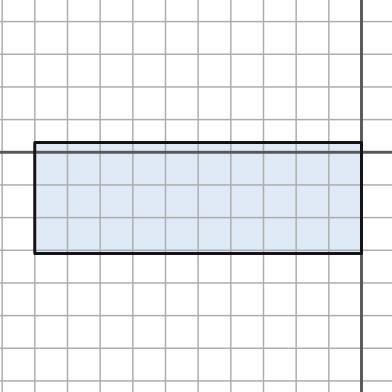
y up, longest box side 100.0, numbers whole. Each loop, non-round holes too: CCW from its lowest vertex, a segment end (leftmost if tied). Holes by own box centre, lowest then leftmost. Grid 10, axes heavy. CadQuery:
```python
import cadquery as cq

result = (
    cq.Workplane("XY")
    .moveTo(-100.0, -31.0)
    .lineTo(0.0, -31.0)
    .lineTo(0.0, 3.0)
    .lineTo(-100.0, 3.0)
    .close()
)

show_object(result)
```